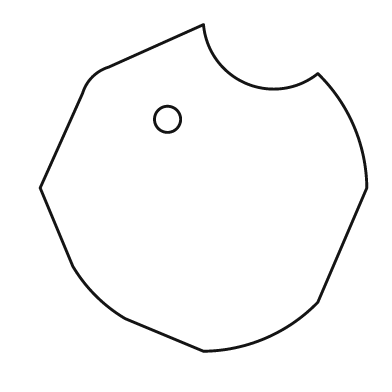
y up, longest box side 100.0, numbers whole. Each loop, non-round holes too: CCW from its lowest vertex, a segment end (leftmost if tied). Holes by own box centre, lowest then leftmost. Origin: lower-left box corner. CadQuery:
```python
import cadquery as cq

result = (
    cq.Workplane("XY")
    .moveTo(50.0, 0.0)
    .threePointArc((69.0, 4.0), (85.0, 15.0))
    .lineTo(100.0, 50.0)
    .threePointArc((96.0, 69.0), (85.0, 85.0))
    .threePointArc((63.0, 82.0), (50.0, 100.0))
    .lineTo(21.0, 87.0)
    .threePointArc((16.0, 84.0), (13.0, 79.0))
    .lineTo(0.0, 50.0)
    .lineTo(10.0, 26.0)
    .threePointArc((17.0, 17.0), (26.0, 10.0))
    .close()
    .moveTo(39.0, 71.0)
    .circle(4.0)
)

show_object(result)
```